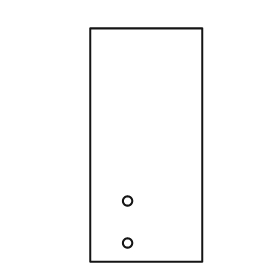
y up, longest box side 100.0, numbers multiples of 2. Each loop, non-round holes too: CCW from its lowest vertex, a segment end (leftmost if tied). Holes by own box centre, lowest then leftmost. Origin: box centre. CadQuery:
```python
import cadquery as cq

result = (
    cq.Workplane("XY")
    .moveTo(-24.0, -50.0)
    .lineTo(24.0, -50.0)
    .lineTo(24.0, 50.0)
    .lineTo(-24.0, 50.0)
    .close()
    .moveTo(-8.0, -42.0)
    .circle(2.0)
    .moveTo(-8.0, -24.0)
    .circle(2.0)
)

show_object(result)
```